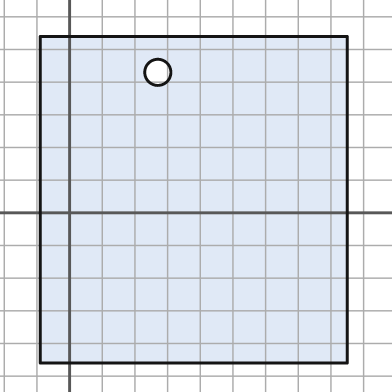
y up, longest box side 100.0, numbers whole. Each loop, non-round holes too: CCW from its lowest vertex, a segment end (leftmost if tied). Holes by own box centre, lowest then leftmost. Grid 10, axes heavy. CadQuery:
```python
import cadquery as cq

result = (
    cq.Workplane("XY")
    .moveTo(-9.0, -46.0)
    .lineTo(85.0, -46.0)
    .lineTo(85.0, 54.0)
    .lineTo(-9.0, 54.0)
    .close()
    .moveTo(27.0, 43.0)
    .circle(4.0)
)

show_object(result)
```